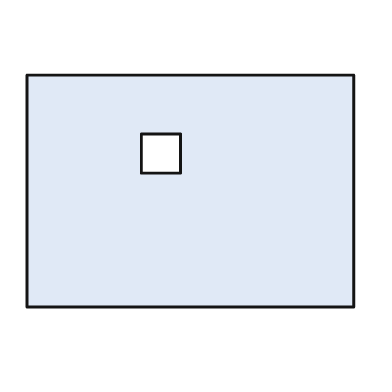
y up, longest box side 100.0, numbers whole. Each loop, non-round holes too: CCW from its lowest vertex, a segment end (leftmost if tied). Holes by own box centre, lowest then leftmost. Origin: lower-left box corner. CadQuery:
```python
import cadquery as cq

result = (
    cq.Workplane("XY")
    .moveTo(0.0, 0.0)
    .lineTo(100.0, 0.0)
    .lineTo(100.0, 71.0)
    .lineTo(0.0, 71.0)
    .close()
    .moveTo(35.0, 41.0)
    .lineTo(47.0, 41.0)
    .lineTo(47.0, 53.0)
    .lineTo(35.0, 53.0)
    .close()
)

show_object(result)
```